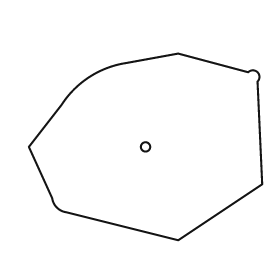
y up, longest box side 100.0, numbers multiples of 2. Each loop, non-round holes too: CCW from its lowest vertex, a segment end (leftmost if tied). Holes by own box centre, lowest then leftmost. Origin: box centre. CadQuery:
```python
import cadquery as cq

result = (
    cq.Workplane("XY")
    .moveTo(14.0, -40.0)
    .lineTo(50.0, -16.0)
    .lineTo(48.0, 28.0)
    .threePointArc((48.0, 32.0), (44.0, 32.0))
    .lineTo(14.0, 40.0)
    .lineTo(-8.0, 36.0)
    .threePointArc((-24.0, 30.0), (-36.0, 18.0))
    .lineTo(-50.0, 0.0)
    .lineTo(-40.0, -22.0)
    .threePointArc((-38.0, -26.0), (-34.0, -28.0))
    .close()
    .moveTo(0.0, 0.0)
    .circle(2.0)
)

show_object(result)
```